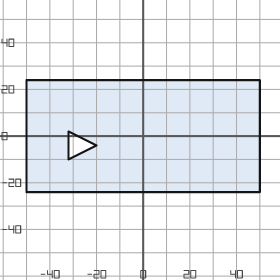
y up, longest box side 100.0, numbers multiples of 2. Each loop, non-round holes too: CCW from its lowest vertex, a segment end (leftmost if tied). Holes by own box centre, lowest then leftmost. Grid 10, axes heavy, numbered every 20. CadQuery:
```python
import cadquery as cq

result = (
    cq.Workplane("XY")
    .moveTo(-50.0, -24.0)
    .lineTo(50.0, -24.0)
    .lineTo(50.0, 24.0)
    .lineTo(-50.0, 24.0)
    .close()
    .moveTo(-32.0, -10.0)
    .lineTo(-20.0, -4.0)
    .lineTo(-32.0, 2.0)
    .close()
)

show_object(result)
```